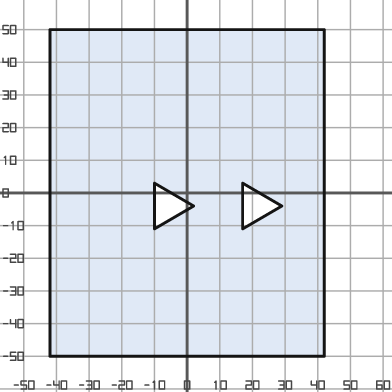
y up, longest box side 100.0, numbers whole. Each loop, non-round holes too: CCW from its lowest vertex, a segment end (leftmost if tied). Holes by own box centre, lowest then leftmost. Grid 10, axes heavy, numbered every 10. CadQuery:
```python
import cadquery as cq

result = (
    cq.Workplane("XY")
    .moveTo(-42.0, -50.0)
    .lineTo(42.0, -50.0)
    .lineTo(42.0, 50.0)
    .lineTo(-42.0, 50.0)
    .close()
    .moveTo(-10.0, -11.0)
    .lineTo(2.0, -4.0)
    .lineTo(-10.0, 3.0)
    .close()
    .moveTo(17.0, -11.0)
    .lineTo(29.0, -4.0)
    .lineTo(17.0, 3.0)
    .close()
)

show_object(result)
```